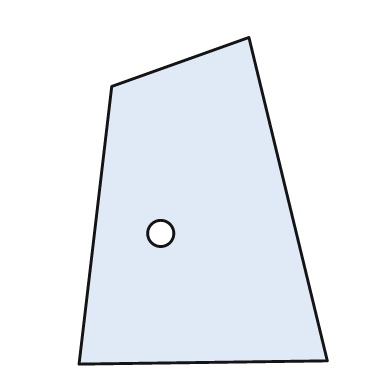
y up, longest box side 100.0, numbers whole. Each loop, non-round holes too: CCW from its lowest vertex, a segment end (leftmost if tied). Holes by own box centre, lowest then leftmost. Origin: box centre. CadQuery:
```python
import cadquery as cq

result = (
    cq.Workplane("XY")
    .moveTo(-38.0, -50.0)
    .lineTo(38.0, -49.0)
    .lineTo(14.0, 50.0)
    .lineTo(-28.0, 35.0)
    .close()
    .moveTo(-13.0, -10.0)
    .circle(4.0)
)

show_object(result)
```